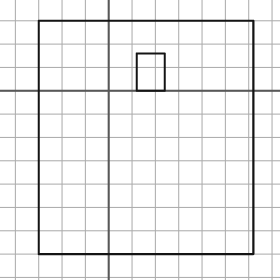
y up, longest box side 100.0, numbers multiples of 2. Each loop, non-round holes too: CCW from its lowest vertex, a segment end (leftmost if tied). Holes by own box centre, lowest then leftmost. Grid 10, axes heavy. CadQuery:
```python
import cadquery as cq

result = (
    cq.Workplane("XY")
    .moveTo(-30.0, -70.0)
    .lineTo(62.0, -70.0)
    .lineTo(62.0, 30.0)
    .lineTo(-30.0, 30.0)
    .close()
    .moveTo(12.0, 0.0)
    .lineTo(24.0, 0.0)
    .lineTo(24.0, 16.0)
    .lineTo(12.0, 16.0)
    .close()
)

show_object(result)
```